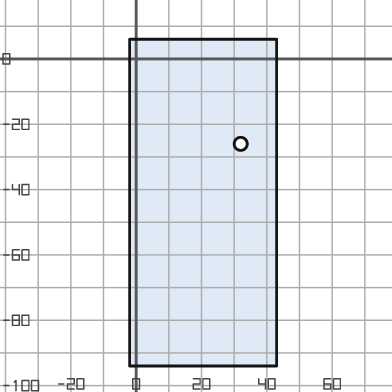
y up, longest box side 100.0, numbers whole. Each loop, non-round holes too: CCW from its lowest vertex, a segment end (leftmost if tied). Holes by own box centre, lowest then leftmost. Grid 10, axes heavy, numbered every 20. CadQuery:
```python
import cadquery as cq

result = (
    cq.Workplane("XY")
    .moveTo(-2.0, -94.0)
    .lineTo(43.0, -94.0)
    .lineTo(43.0, 6.0)
    .lineTo(-2.0, 6.0)
    .close()
    .moveTo(32.0, -26.0)
    .circle(2.0)
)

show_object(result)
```